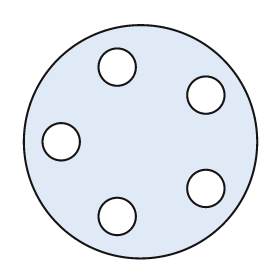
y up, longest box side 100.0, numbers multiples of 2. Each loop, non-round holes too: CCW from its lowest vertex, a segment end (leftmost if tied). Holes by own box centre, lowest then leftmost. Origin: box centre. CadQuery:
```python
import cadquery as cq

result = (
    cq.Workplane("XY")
    .moveTo(0.0, 0.0)
    .circle(50.0)
    .moveTo(-10.0, -32.0)
    .circle(8.0)
    .moveTo(28.0, -20.0)
    .circle(8.0)
    .moveTo(-34.0, 0.0)
    .circle(8.0)
    .moveTo(28.0, 20.0)
    .circle(8.0)
    .moveTo(-10.0, 32.0)
    .circle(8.0)
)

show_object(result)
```